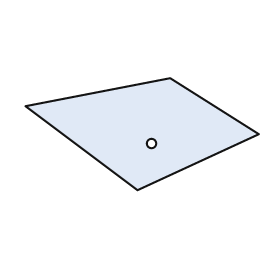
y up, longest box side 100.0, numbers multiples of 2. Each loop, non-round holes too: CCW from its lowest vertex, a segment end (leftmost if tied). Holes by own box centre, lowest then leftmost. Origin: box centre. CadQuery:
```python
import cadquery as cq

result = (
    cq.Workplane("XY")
    .moveTo(-2.0, -24.0)
    .lineTo(50.0, 0.0)
    .lineTo(12.0, 24.0)
    .lineTo(-50.0, 12.0)
    .close()
    .moveTo(4.0, -4.0)
    .circle(2.0)
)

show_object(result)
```